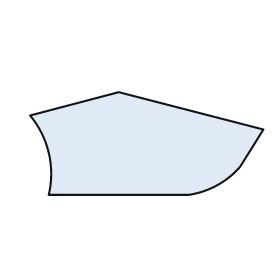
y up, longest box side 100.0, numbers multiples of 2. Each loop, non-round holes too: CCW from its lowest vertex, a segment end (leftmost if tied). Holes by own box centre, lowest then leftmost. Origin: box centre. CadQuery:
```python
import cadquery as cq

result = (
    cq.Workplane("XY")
    .moveTo(-42.0, -22.0)
    .lineTo(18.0, -22.0)
    .threePointArc((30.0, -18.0), (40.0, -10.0))
    .lineTo(50.0, 6.0)
    .lineTo(-12.0, 22.0)
    .lineTo(-50.0, 12.0)
    .threePointArc((-42.0, -4.0), (-42.0, -22.0))
    .close()
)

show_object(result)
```